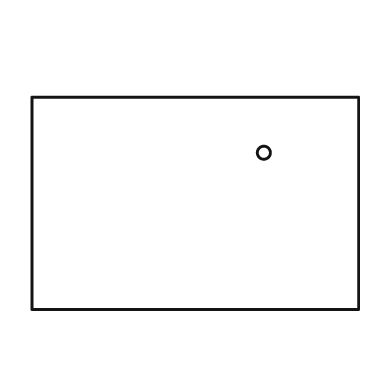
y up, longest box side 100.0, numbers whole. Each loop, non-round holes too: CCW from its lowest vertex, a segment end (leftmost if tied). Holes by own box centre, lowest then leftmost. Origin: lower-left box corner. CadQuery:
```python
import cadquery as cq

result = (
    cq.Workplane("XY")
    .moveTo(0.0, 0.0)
    .lineTo(100.0, 0.0)
    .lineTo(100.0, 65.0)
    .lineTo(0.0, 65.0)
    .close()
    .moveTo(71.0, 48.0)
    .circle(2.0)
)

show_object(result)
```